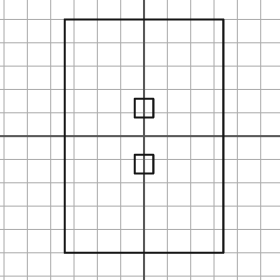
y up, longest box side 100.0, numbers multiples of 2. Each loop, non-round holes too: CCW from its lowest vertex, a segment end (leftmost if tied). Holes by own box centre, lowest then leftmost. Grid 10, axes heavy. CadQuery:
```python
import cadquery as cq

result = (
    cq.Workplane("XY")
    .moveTo(-34.0, -50.0)
    .lineTo(34.0, -50.0)
    .lineTo(34.0, 50.0)
    .lineTo(-34.0, 50.0)
    .close()
    .moveTo(-4.0, -16.0)
    .lineTo(4.0, -16.0)
    .lineTo(4.0, -8.0)
    .lineTo(-4.0, -8.0)
    .close()
    .moveTo(-4.0, 8.0)
    .lineTo(4.0, 8.0)
    .lineTo(4.0, 16.0)
    .lineTo(-4.0, 16.0)
    .close()
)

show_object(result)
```